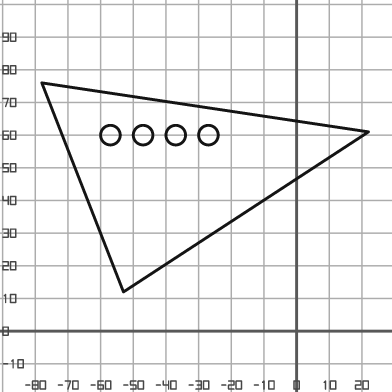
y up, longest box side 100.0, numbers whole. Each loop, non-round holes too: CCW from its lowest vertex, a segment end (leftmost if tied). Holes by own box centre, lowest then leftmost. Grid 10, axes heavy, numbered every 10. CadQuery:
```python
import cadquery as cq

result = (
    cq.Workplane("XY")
    .moveTo(-53.0, 12.0)
    .lineTo(22.0, 61.0)
    .lineTo(-78.0, 76.0)
    .close()
    .moveTo(-57.0, 60.0)
    .circle(3.0)
    .moveTo(-47.0, 60.0)
    .circle(3.0)
    .moveTo(-37.0, 60.0)
    .circle(3.0)
    .moveTo(-27.0, 60.0)
    .circle(3.0)
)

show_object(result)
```